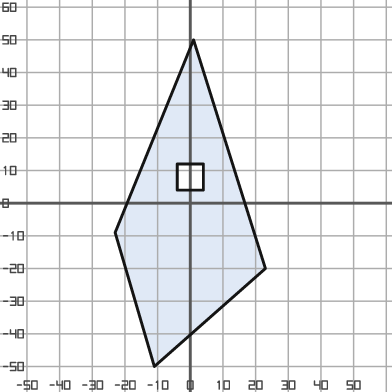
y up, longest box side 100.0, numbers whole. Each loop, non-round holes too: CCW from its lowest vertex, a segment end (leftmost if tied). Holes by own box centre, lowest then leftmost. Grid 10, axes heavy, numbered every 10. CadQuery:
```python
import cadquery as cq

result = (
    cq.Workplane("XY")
    .moveTo(-11.0, -50.0)
    .lineTo(23.0, -20.0)
    .lineTo(1.0, 50.0)
    .lineTo(-23.0, -9.0)
    .close()
    .moveTo(-4.0, 4.0)
    .lineTo(4.0, 4.0)
    .lineTo(4.0, 12.0)
    .lineTo(-4.0, 12.0)
    .close()
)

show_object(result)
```